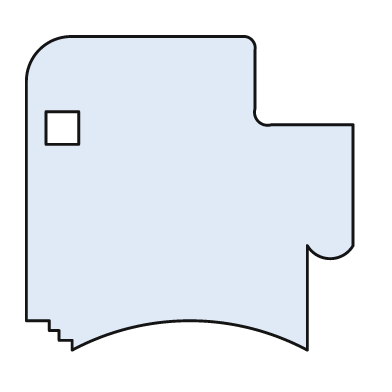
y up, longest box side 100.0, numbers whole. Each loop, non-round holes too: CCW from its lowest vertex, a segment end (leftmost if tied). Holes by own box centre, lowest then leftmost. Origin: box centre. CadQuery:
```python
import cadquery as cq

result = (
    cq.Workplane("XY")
    .moveTo(-36.0, -48.0)
    .threePointArc((0.0, -39.0), (36.0, -48.0))
    .lineTo(36.0, -16.0)
    .threePointArc((43.0, -20.0), (50.0, -16.0))
    .lineTo(50.0, 21.0)
    .lineTo(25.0, 21.0)
    .threePointArc((21.0, 22.0), (20.0, 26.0))
    .lineTo(20.0, 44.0)
    .threePointArc((19.0, 47.0), (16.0, 48.0))
    .lineTo(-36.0, 48.0)
    .threePointArc((-46.0, 44.0), (-50.0, 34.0))
    .lineTo(-50.0, -39.0)
    .lineTo(-43.0, -39.0)
    .lineTo(-43.0, -42.0)
    .lineTo(-40.0, -42.0)
    .lineTo(-40.0, -45.0)
    .lineTo(-36.0, -45.0)
    .close()
    .moveTo(-44.0, 15.0)
    .lineTo(-34.0, 15.0)
    .lineTo(-34.0, 25.0)
    .lineTo(-44.0, 25.0)
    .close()
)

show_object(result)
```